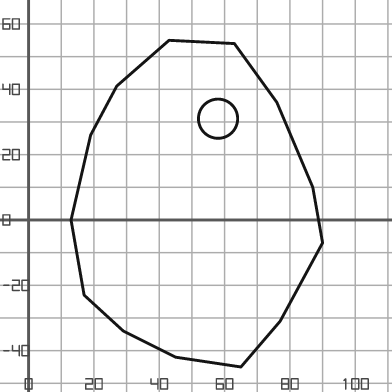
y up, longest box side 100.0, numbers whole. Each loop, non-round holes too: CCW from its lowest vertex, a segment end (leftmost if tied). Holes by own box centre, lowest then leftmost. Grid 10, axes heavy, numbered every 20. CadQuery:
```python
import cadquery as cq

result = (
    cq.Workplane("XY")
    .moveTo(65.0, -45.0)
    .lineTo(77.0, -31.0)
    .lineTo(90.0, -7.0)
    .lineTo(87.0, 10.0)
    .lineTo(76.0, 36.0)
    .lineTo(63.0, 54.0)
    .lineTo(43.0, 55.0)
    .lineTo(27.0, 41.0)
    .lineTo(19.0, 26.0)
    .lineTo(13.0, 0.0)
    .lineTo(17.0, -23.0)
    .lineTo(29.0, -34.0)
    .lineTo(45.0, -42.0)
    .close()
    .moveTo(58.0, 31.0)
    .circle(6.0)
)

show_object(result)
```